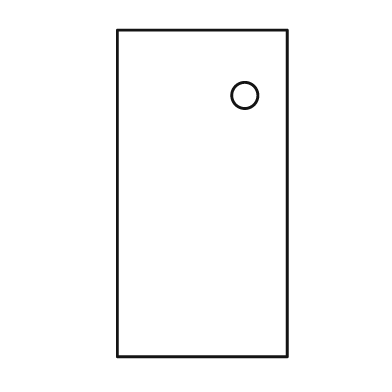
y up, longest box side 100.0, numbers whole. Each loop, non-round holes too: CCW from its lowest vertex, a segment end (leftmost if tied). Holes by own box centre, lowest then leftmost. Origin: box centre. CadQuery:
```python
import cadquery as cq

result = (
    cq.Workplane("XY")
    .moveTo(-26.0, -50.0)
    .lineTo(26.0, -50.0)
    .lineTo(26.0, 50.0)
    .lineTo(-26.0, 50.0)
    .close()
    .moveTo(13.0, 30.0)
    .circle(4.0)
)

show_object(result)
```